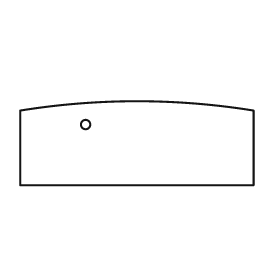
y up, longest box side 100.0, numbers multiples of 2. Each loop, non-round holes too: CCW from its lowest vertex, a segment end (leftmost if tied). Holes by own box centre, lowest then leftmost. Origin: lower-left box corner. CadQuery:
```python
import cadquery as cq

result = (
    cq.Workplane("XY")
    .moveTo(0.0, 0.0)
    .lineTo(100.0, 0.0)
    .lineTo(100.0, 32.0)
    .threePointArc((50.0, 36.0), (0.0, 32.0))
    .close()
    .moveTo(28.0, 26.0)
    .circle(2.0)
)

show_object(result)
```